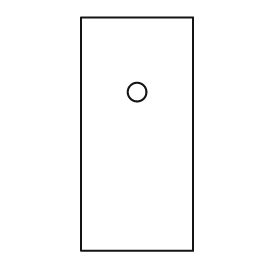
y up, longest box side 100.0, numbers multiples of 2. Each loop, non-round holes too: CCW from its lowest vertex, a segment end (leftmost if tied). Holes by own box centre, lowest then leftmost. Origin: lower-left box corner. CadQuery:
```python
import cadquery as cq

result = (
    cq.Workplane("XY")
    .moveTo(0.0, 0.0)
    .lineTo(48.0, 0.0)
    .lineTo(48.0, 100.0)
    .lineTo(0.0, 100.0)
    .close()
    .moveTo(24.0, 68.0)
    .circle(4.0)
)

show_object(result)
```